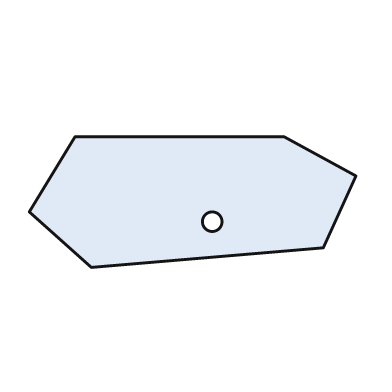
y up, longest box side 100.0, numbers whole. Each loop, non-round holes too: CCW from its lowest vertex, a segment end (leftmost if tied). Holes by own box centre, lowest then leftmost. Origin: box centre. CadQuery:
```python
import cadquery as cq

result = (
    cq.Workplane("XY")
    .moveTo(-31.0, -20.0)
    .lineTo(40.0, -14.0)
    .lineTo(50.0, 8.0)
    .lineTo(28.0, 20.0)
    .lineTo(-36.0, 20.0)
    .lineTo(-50.0, -3.0)
    .close()
    .moveTo(6.0, -6.0)
    .circle(3.0)
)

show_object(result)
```